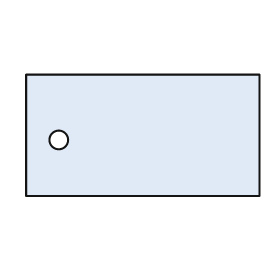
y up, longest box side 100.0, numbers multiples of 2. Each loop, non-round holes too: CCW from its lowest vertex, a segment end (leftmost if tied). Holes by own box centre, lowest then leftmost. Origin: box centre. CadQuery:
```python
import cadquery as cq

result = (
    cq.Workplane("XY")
    .moveTo(-50.0, -26.0)
    .lineTo(50.0, -26.0)
    .lineTo(50.0, 26.0)
    .lineTo(-50.0, 26.0)
    .close()
    .moveTo(-36.0, -2.0)
    .circle(4.0)
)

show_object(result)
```